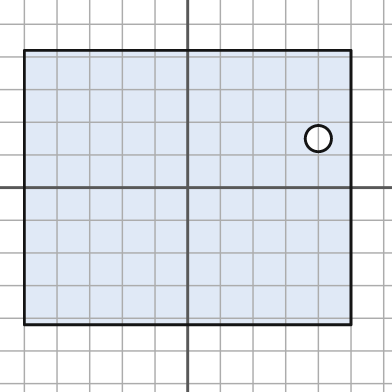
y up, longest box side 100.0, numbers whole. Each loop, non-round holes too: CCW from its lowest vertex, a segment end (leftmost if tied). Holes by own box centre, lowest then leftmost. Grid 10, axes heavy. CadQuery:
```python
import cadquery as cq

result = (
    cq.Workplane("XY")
    .moveTo(-50.0, -42.0)
    .lineTo(50.0, -42.0)
    .lineTo(50.0, 42.0)
    .lineTo(-50.0, 42.0)
    .close()
    .moveTo(40.0, 15.0)
    .circle(4.0)
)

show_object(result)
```